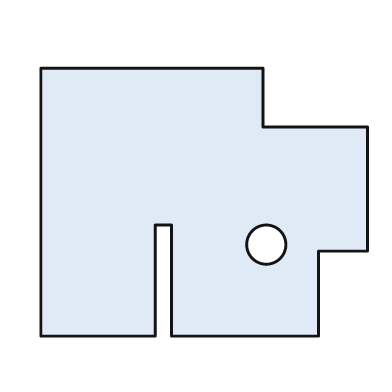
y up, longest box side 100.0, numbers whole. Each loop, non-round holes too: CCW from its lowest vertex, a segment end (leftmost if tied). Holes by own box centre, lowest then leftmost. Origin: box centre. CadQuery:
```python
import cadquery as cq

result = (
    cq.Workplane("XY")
    .moveTo(-50.0, -41.0)
    .lineTo(-15.0, -41.0)
    .lineTo(-15.0, -7.0)
    .lineTo(-10.0, -7.0)
    .lineTo(-10.0, -41.0)
    .lineTo(35.0, -41.0)
    .lineTo(35.0, -15.0)
    .lineTo(50.0, -15.0)
    .lineTo(50.0, 23.0)
    .lineTo(18.0, 23.0)
    .lineTo(18.0, 41.0)
    .lineTo(-50.0, 41.0)
    .close()
    .moveTo(19.0, -13.0)
    .circle(6.0)
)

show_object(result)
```